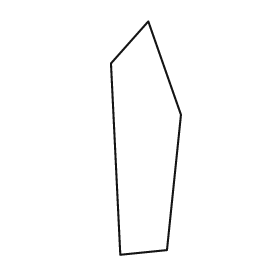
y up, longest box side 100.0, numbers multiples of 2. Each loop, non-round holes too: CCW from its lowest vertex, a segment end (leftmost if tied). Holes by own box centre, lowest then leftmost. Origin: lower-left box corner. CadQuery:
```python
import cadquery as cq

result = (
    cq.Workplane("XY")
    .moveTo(4.0, 0.0)
    .lineTo(24.0, 2.0)
    .lineTo(30.0, 60.0)
    .lineTo(16.0, 100.0)
    .lineTo(0.0, 82.0)
    .close()
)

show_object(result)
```